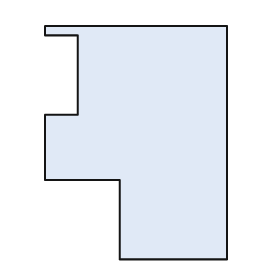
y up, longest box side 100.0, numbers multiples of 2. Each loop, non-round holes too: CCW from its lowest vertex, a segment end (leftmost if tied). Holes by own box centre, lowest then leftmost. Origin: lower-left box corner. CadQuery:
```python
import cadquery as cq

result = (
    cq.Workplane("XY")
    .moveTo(32.0, 0.0)
    .lineTo(78.0, 0.0)
    .lineTo(78.0, 100.0)
    .lineTo(0.0, 100.0)
    .lineTo(0.0, 96.0)
    .lineTo(14.0, 96.0)
    .lineTo(14.0, 62.0)
    .lineTo(0.0, 62.0)
    .lineTo(0.0, 34.0)
    .lineTo(32.0, 34.0)
    .close()
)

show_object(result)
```